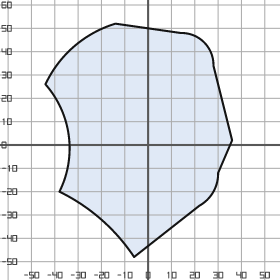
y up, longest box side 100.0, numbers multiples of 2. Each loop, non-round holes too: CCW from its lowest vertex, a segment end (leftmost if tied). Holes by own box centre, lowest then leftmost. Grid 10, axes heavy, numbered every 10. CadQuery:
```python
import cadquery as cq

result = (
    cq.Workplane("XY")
    .moveTo(-6.0, -48.0)
    .lineTo(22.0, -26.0)
    .threePointArc((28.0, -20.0), (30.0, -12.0))
    .lineTo(36.0, 2.0)
    .lineTo(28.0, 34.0)
    .threePointArc((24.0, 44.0), (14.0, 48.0))
    .lineTo(-14.0, 52.0)
    .threePointArc((-32.0, 42.0), (-44.0, 26.0))
    .threePointArc((-34.0, 4.0), (-38.0, -20.0))
    .threePointArc((-20.0, -32.0), (-6.0, -48.0))
    .close()
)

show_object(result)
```